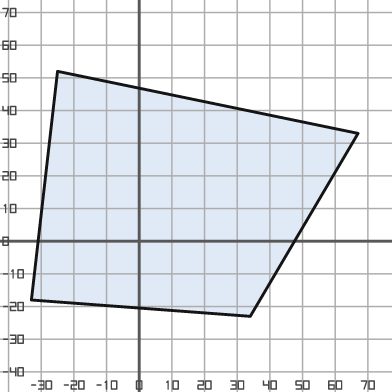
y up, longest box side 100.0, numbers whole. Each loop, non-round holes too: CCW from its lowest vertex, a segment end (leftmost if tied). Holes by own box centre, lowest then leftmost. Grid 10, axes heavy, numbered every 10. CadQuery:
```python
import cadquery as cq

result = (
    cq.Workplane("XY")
    .moveTo(34.0, -23.0)
    .lineTo(67.0, 33.0)
    .lineTo(-25.0, 52.0)
    .lineTo(-33.0, -18.0)
    .close()
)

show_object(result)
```